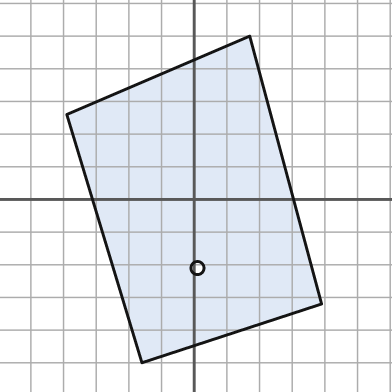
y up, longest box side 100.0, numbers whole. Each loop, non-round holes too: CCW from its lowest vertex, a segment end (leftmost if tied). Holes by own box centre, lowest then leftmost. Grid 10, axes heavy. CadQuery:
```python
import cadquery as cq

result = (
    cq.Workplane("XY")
    .moveTo(-16.0, -50.0)
    .lineTo(39.0, -32.0)
    .lineTo(17.0, 50.0)
    .lineTo(-39.0, 26.0)
    .close()
    .moveTo(1.0, -21.0)
    .circle(2.0)
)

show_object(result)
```